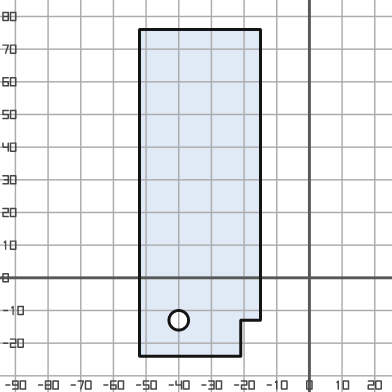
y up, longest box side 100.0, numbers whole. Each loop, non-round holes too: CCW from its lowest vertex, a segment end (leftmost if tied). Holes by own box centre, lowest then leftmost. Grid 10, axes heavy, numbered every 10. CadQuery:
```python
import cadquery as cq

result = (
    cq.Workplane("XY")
    .moveTo(-52.0, -24.0)
    .lineTo(-21.0, -24.0)
    .lineTo(-21.0, -13.0)
    .lineTo(-15.0, -13.0)
    .lineTo(-15.0, 76.0)
    .lineTo(-52.0, 76.0)
    .close()
    .moveTo(-40.0, -13.0)
    .circle(3.0)
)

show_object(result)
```